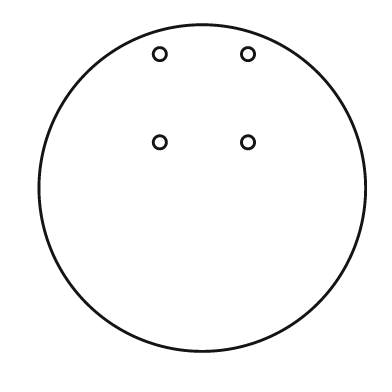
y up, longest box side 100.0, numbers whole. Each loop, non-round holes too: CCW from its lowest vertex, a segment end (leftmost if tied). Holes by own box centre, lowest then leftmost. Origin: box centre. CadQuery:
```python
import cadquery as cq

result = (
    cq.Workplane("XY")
    .moveTo(0.0, 0.0)
    .circle(50.0)
    .moveTo(-13.0, 14.0)
    .circle(2.0)
    .moveTo(14.0, 14.0)
    .circle(2.0)
    .moveTo(-13.0, 41.0)
    .circle(2.0)
    .moveTo(14.0, 41.0)
    .circle(2.0)
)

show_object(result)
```